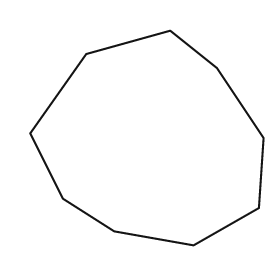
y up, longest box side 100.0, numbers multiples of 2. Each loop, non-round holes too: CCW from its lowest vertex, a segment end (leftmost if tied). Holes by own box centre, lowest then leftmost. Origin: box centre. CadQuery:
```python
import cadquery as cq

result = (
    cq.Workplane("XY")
    .moveTo(20.0, -46.0)
    .lineTo(48.0, -30.0)
    .lineTo(50.0, 0.0)
    .lineTo(30.0, 30.0)
    .lineTo(10.0, 46.0)
    .lineTo(-26.0, 36.0)
    .lineTo(-50.0, 2.0)
    .lineTo(-36.0, -26.0)
    .lineTo(-14.0, -40.0)
    .close()
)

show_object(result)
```